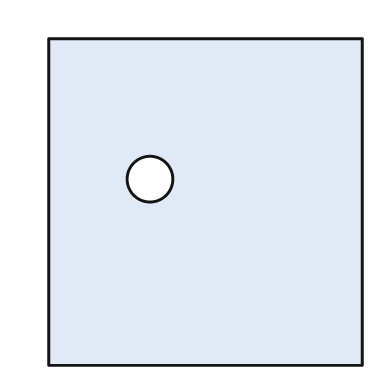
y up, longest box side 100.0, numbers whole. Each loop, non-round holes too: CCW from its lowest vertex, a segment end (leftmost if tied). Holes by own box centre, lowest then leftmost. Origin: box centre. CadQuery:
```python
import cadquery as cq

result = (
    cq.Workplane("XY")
    .moveTo(-48.0, -50.0)
    .lineTo(48.0, -50.0)
    .lineTo(48.0, 50.0)
    .lineTo(-48.0, 50.0)
    .close()
    .moveTo(-17.0, 7.0)
    .circle(7.0)
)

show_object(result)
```